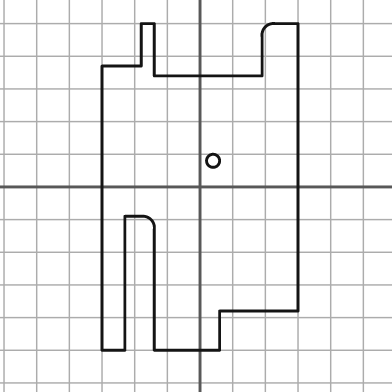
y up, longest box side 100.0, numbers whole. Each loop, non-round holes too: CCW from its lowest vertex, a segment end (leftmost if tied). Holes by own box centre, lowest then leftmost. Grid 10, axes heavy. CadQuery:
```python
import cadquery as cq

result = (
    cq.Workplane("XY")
    .moveTo(-30.0, -50.0)
    .lineTo(-23.0, -50.0)
    .lineTo(-23.0, -9.0)
    .lineTo(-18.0, -9.0)
    .threePointArc((-15.0, -10.0), (-14.0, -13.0))
    .lineTo(-14.0, -50.0)
    .lineTo(6.0, -50.0)
    .lineTo(6.0, -38.0)
    .lineTo(30.0, -38.0)
    .lineTo(30.0, 50.0)
    .lineTo(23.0, 50.0)
    .threePointArc((20.0, 49.0), (19.0, 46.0))
    .lineTo(19.0, 34.0)
    .lineTo(-14.0, 34.0)
    .lineTo(-14.0, 50.0)
    .lineTo(-18.0, 50.0)
    .lineTo(-18.0, 37.0)
    .lineTo(-30.0, 37.0)
    .close()
    .moveTo(4.0, 8.0)
    .circle(2.0)
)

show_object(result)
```